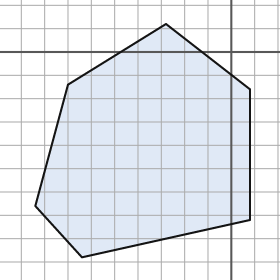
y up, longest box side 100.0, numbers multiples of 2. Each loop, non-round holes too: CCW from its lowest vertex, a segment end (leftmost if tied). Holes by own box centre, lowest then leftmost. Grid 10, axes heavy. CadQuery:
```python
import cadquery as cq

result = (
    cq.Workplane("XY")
    .moveTo(-64.0, -88.0)
    .lineTo(8.0, -72.0)
    .lineTo(8.0, -16.0)
    .lineTo(-28.0, 12.0)
    .lineTo(-70.0, -14.0)
    .lineTo(-84.0, -66.0)
    .close()
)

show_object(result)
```